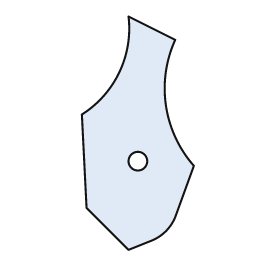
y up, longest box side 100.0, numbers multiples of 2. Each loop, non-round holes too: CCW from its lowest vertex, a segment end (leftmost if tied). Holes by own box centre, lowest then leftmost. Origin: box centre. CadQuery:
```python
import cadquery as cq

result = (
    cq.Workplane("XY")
    .moveTo(-4.0, -50.0)
    .lineTo(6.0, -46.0)
    .threePointArc((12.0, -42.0), (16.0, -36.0))
    .lineTo(24.0, -14.0)
    .threePointArc((12.0, 12.0), (16.0, 40.0))
    .lineTo(-4.0, 50.0)
    .threePointArc((-8.0, 26.0), (-24.0, 8.0))
    .lineTo(-22.0, -32.0)
    .close()
    .moveTo(0.0, -12.0)
    .circle(4.0)
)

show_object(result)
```